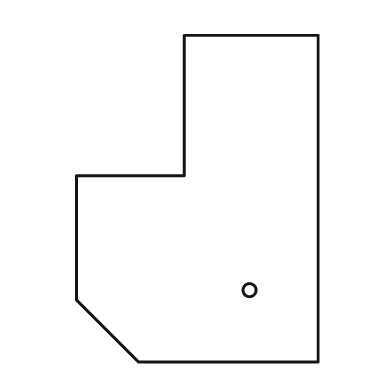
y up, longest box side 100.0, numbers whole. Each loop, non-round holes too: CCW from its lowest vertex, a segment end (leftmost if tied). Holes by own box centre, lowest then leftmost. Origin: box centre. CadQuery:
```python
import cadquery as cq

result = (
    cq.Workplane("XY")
    .moveTo(-18.0, -50.0)
    .lineTo(37.0, -50.0)
    .lineTo(37.0, 50.0)
    .lineTo(-4.0, 50.0)
    .lineTo(-4.0, 7.0)
    .lineTo(-37.0, 7.0)
    .lineTo(-37.0, -31.0)
    .close()
    .moveTo(16.0, -28.0)
    .circle(2.0)
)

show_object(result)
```